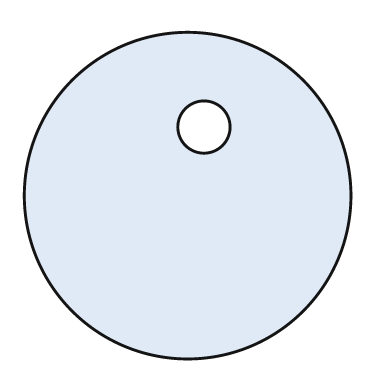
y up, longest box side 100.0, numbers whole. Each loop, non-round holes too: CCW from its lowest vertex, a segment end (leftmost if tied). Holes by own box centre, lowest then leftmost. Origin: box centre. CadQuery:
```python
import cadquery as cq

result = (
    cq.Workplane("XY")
    .moveTo(0.0, 0.0)
    .circle(50.0)
    .moveTo(5.0, 21.0)
    .circle(8.0)
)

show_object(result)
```